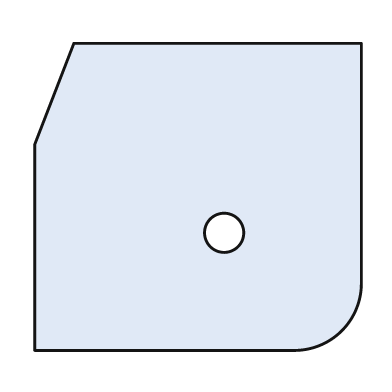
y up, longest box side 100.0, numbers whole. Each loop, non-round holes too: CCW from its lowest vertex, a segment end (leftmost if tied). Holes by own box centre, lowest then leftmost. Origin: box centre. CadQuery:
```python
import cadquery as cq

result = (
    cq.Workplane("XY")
    .moveTo(-50.0, -47.0)
    .lineTo(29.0, -47.0)
    .threePointArc((44.0, -41.0), (50.0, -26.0))
    .lineTo(50.0, 47.0)
    .lineTo(-38.0, 47.0)
    .lineTo(-50.0, 16.0)
    .close()
    .moveTo(8.0, -11.0)
    .circle(6.0)
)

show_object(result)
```